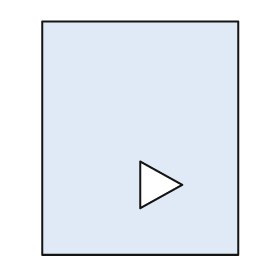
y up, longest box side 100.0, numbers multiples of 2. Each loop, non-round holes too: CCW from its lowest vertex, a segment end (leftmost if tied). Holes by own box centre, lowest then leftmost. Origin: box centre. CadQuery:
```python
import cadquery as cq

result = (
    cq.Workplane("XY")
    .moveTo(-42.0, -50.0)
    .lineTo(42.0, -50.0)
    .lineTo(42.0, 50.0)
    .lineTo(-42.0, 50.0)
    .close()
    .moveTo(0.0, -30.0)
    .lineTo(18.0, -20.0)
    .lineTo(0.0, -10.0)
    .close()
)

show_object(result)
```